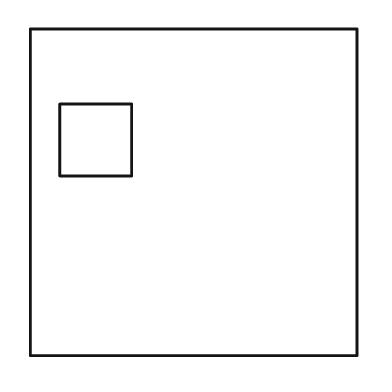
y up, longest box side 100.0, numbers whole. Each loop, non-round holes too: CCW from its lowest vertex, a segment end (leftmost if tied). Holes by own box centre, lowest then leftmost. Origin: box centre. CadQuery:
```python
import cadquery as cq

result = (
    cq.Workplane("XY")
    .moveTo(-50.0, -50.0)
    .lineTo(50.0, -50.0)
    .lineTo(50.0, 50.0)
    .lineTo(-50.0, 50.0)
    .close()
    .moveTo(-41.0, 5.0)
    .lineTo(-19.0, 5.0)
    .lineTo(-19.0, 27.0)
    .lineTo(-41.0, 27.0)
    .close()
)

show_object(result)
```